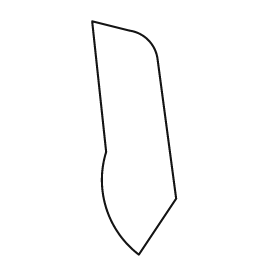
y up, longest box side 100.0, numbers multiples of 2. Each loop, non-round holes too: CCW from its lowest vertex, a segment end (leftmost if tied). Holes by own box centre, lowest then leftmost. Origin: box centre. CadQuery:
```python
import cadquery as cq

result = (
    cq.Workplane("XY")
    .moveTo(2.0, -50.0)
    .lineTo(18.0, -26.0)
    .lineTo(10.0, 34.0)
    .threePointArc((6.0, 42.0), (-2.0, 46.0))
    .lineTo(-18.0, 50.0)
    .lineTo(-12.0, -6.0)
    .threePointArc((-12.0, -30.0), (2.0, -50.0))
    .close()
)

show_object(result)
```